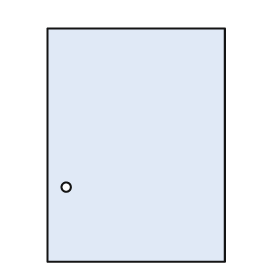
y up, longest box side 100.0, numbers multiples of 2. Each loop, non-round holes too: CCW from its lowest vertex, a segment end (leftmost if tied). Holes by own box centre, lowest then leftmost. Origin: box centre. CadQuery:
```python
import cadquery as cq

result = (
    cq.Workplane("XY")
    .moveTo(-38.0, -50.0)
    .lineTo(38.0, -50.0)
    .lineTo(38.0, 50.0)
    .lineTo(-38.0, 50.0)
    .close()
    .moveTo(-30.0, -18.0)
    .circle(2.0)
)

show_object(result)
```